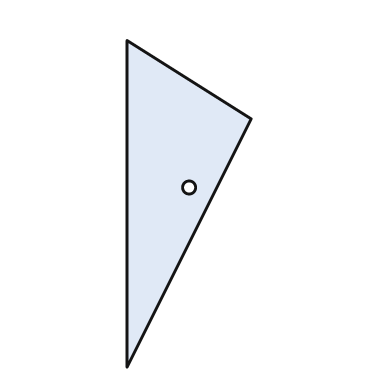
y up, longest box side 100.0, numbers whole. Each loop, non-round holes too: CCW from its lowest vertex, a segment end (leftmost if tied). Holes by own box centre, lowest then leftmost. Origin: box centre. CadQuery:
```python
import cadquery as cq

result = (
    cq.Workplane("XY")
    .moveTo(-19.0, -50.0)
    .lineTo(19.0, 26.0)
    .lineTo(-19.0, 50.0)
    .close()
    .moveTo(0.0, 5.0)
    .circle(2.0)
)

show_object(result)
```